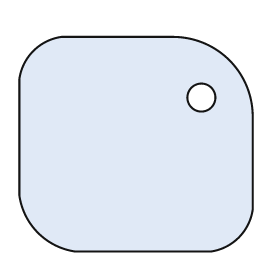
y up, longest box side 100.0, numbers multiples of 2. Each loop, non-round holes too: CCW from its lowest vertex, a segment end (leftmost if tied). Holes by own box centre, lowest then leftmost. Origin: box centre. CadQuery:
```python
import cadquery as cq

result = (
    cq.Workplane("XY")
    .moveTo(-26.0, -46.0)
    .lineTo(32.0, -46.0)
    .threePointArc((44.0, -40.0), (50.0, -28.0))
    .lineTo(50.0, 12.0)
    .threePointArc((40.0, 36.0), (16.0, 46.0))
    .lineTo(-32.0, 46.0)
    .threePointArc((-44.0, 40.0), (-50.0, 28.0))
    .lineTo(-50.0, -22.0)
    .threePointArc((-42.0, -38.0), (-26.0, -46.0))
    .close()
    .moveTo(28.0, 20.0)
    .circle(6.0)
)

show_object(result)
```